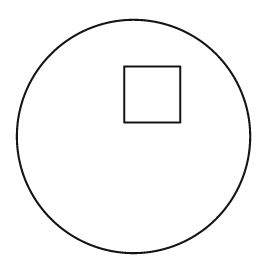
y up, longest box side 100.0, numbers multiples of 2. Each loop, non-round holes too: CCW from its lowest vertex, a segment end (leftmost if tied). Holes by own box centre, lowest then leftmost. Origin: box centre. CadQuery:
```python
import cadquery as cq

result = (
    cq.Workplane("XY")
    .moveTo(0.0, 0.0)
    .circle(50.0)
    .moveTo(-4.0, 6.0)
    .lineTo(20.0, 6.0)
    .lineTo(20.0, 30.0)
    .lineTo(-4.0, 30.0)
    .close()
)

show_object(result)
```